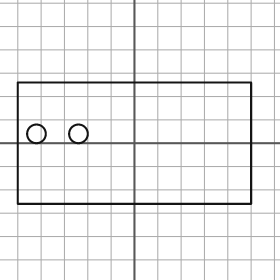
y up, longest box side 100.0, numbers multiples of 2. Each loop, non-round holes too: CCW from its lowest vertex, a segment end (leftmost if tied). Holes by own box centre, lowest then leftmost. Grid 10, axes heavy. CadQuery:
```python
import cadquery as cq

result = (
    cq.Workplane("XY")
    .moveTo(-50.0, -26.0)
    .lineTo(50.0, -26.0)
    .lineTo(50.0, 26.0)
    .lineTo(-50.0, 26.0)
    .close()
    .moveTo(-42.0, 4.0)
    .circle(4.0)
    .moveTo(-24.0, 4.0)
    .circle(4.0)
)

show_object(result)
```